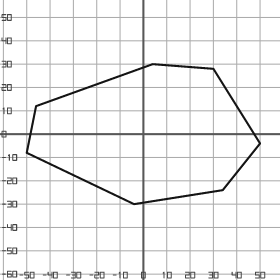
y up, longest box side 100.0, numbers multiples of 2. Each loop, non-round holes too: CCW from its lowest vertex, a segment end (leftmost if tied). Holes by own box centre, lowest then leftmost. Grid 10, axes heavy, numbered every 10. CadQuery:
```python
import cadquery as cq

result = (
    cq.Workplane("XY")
    .moveTo(-4.0, -30.0)
    .lineTo(34.0, -24.0)
    .lineTo(50.0, -4.0)
    .lineTo(30.0, 28.0)
    .lineTo(4.0, 30.0)
    .lineTo(-46.0, 12.0)
    .lineTo(-50.0, -8.0)
    .close()
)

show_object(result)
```